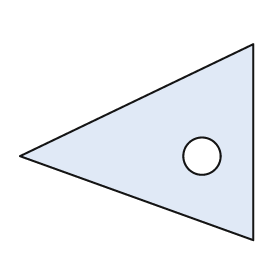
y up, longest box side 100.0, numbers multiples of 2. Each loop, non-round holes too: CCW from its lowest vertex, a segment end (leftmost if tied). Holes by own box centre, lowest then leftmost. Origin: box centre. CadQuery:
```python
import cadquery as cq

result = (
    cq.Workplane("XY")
    .moveTo(50.0, -42.0)
    .lineTo(50.0, 42.0)
    .lineTo(-50.0, -6.0)
    .close()
    .moveTo(28.0, -6.0)
    .circle(8.0)
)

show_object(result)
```